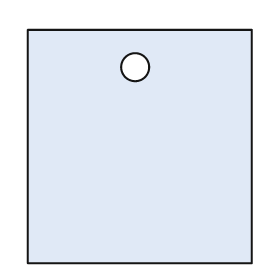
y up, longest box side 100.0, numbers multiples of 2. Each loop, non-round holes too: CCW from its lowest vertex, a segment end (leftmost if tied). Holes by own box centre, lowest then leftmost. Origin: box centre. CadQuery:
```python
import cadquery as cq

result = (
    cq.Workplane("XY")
    .moveTo(-48.0, -50.0)
    .lineTo(48.0, -50.0)
    .lineTo(48.0, 50.0)
    .lineTo(-48.0, 50.0)
    .close()
    .moveTo(-2.0, 34.0)
    .circle(6.0)
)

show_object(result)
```